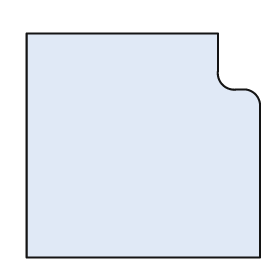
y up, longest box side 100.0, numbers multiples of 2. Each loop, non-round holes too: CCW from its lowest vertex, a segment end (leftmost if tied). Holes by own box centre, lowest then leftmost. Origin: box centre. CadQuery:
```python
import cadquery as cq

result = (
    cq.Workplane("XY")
    .moveTo(-50.0, -48.0)
    .lineTo(50.0, -48.0)
    .lineTo(50.0, 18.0)
    .threePointArc((48.0, 22.0), (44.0, 24.0))
    .lineTo(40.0, 24.0)
    .threePointArc((34.0, 26.0), (32.0, 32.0))
    .lineTo(32.0, 48.0)
    .lineTo(-50.0, 48.0)
    .close()
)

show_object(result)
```